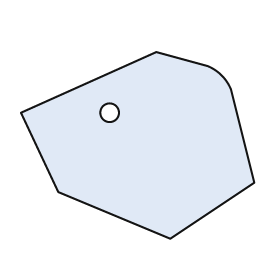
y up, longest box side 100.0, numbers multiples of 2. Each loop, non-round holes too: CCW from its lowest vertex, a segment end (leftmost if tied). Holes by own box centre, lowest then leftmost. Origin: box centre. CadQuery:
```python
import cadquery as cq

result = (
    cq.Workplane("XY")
    .moveTo(14.0, -40.0)
    .lineTo(50.0, -16.0)
    .lineTo(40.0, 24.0)
    .threePointArc((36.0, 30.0), (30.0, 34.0))
    .lineTo(8.0, 40.0)
    .lineTo(-50.0, 14.0)
    .lineTo(-34.0, -20.0)
    .close()
    .moveTo(-12.0, 14.0)
    .circle(4.0)
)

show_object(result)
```